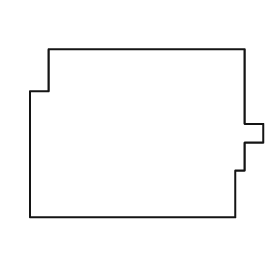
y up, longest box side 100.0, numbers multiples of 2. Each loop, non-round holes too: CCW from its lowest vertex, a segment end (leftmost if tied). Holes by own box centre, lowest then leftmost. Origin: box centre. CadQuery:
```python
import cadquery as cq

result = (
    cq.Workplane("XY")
    .moveTo(-50.0, -36.0)
    .lineTo(38.0, -36.0)
    .lineTo(38.0, -16.0)
    .lineTo(42.0, -16.0)
    .lineTo(42.0, -4.0)
    .lineTo(50.0, -4.0)
    .lineTo(50.0, 4.0)
    .lineTo(42.0, 4.0)
    .lineTo(42.0, 36.0)
    .lineTo(-42.0, 36.0)
    .lineTo(-42.0, 18.0)
    .lineTo(-50.0, 18.0)
    .close()
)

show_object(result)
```